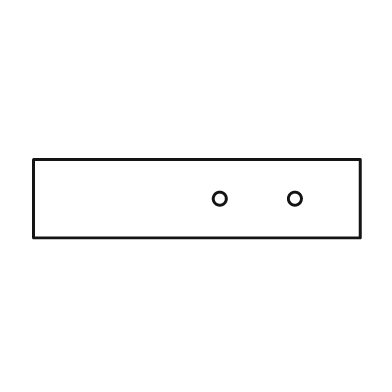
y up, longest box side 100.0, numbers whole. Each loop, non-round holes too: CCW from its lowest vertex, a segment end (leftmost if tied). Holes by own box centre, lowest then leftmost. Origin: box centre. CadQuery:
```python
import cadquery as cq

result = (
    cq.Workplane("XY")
    .moveTo(-50.0, -12.0)
    .lineTo(50.0, -12.0)
    .lineTo(50.0, 12.0)
    .lineTo(-50.0, 12.0)
    .close()
    .moveTo(7.0, 0.0)
    .circle(2.0)
    .moveTo(30.0, 0.0)
    .circle(2.0)
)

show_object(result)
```